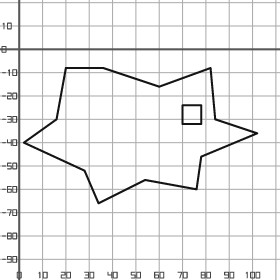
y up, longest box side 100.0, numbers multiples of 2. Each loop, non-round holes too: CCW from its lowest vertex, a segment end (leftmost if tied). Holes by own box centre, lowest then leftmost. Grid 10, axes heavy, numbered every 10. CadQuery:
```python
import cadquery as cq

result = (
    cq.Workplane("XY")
    .moveTo(34.0, -66.0)
    .lineTo(54.0, -56.0)
    .lineTo(76.0, -60.0)
    .lineTo(78.0, -46.0)
    .lineTo(102.0, -36.0)
    .lineTo(84.0, -30.0)
    .lineTo(82.0, -8.0)
    .lineTo(60.0, -16.0)
    .lineTo(36.0, -8.0)
    .lineTo(20.0, -8.0)
    .lineTo(16.0, -30.0)
    .lineTo(2.0, -40.0)
    .lineTo(28.0, -52.0)
    .close()
    .moveTo(70.0, -32.0)
    .lineTo(78.0, -32.0)
    .lineTo(78.0, -24.0)
    .lineTo(70.0, -24.0)
    .close()
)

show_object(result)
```